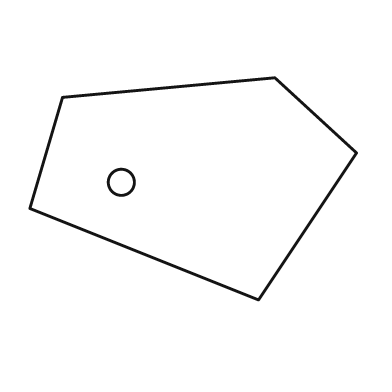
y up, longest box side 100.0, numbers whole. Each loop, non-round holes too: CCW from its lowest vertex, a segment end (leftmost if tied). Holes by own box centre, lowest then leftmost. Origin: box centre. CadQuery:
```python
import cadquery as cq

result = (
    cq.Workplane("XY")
    .moveTo(20.0, -34.0)
    .lineTo(50.0, 11.0)
    .lineTo(25.0, 34.0)
    .lineTo(-40.0, 28.0)
    .lineTo(-50.0, -6.0)
    .close()
    .moveTo(-22.0, 2.0)
    .circle(4.0)
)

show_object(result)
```